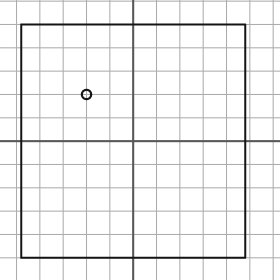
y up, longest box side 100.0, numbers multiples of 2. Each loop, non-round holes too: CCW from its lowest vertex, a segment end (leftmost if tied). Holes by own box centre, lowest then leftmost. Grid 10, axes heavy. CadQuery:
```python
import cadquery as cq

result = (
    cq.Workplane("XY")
    .moveTo(-48.0, -50.0)
    .lineTo(48.0, -50.0)
    .lineTo(48.0, 50.0)
    .lineTo(-48.0, 50.0)
    .close()
    .moveTo(-20.0, 20.0)
    .circle(2.0)
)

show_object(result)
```